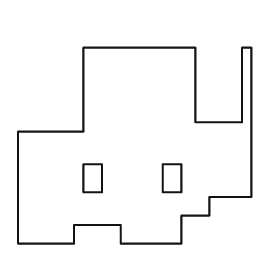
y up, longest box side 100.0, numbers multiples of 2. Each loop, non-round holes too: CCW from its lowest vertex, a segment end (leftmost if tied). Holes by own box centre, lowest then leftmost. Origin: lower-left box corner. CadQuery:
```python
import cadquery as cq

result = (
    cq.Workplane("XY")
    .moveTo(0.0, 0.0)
    .lineTo(24.0, 0.0)
    .lineTo(24.0, 8.0)
    .lineTo(44.0, 8.0)
    .lineTo(44.0, 0.0)
    .lineTo(70.0, 0.0)
    .lineTo(70.0, 12.0)
    .lineTo(82.0, 12.0)
    .lineTo(82.0, 20.0)
    .lineTo(100.0, 20.0)
    .lineTo(100.0, 84.0)
    .lineTo(96.0, 84.0)
    .lineTo(96.0, 52.0)
    .lineTo(76.0, 52.0)
    .lineTo(76.0, 84.0)
    .lineTo(28.0, 84.0)
    .lineTo(28.0, 48.0)
    .lineTo(0.0, 48.0)
    .close()
    .moveTo(28.0, 22.0)
    .lineTo(36.0, 22.0)
    .lineTo(36.0, 34.0)
    .lineTo(28.0, 34.0)
    .close()
    .moveTo(62.0, 22.0)
    .lineTo(70.0, 22.0)
    .lineTo(70.0, 34.0)
    .lineTo(62.0, 34.0)
    .close()
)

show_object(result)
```